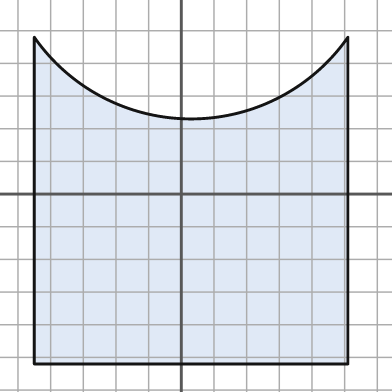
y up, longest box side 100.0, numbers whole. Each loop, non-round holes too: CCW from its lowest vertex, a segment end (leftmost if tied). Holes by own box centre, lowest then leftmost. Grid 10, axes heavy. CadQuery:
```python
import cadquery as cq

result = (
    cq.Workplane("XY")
    .moveTo(-45.0, -52.0)
    .lineTo(51.0, -52.0)
    .lineTo(51.0, 48.0)
    .threePointArc((3.0, 23.0), (-45.0, 48.0))
    .close()
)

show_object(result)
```